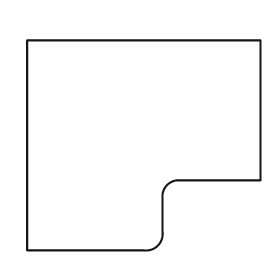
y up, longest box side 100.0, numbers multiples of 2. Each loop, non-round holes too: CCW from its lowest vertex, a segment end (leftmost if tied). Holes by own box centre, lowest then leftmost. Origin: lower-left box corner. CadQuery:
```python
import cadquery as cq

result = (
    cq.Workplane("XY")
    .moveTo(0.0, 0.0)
    .lineTo(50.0, 0.0)
    .threePointArc((56.0, 2.0), (58.0, 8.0))
    .lineTo(58.0, 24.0)
    .threePointArc((60.0, 28.0), (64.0, 30.0))
    .lineTo(100.0, 30.0)
    .lineTo(100.0, 90.0)
    .lineTo(0.0, 90.0)
    .close()
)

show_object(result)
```